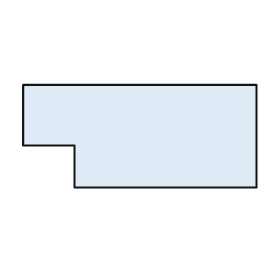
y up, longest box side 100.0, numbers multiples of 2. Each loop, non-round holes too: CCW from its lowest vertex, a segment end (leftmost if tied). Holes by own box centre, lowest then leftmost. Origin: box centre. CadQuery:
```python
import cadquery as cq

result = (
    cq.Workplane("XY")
    .moveTo(-28.0, -22.0)
    .lineTo(50.0, -22.0)
    .lineTo(50.0, 22.0)
    .lineTo(-50.0, 22.0)
    .lineTo(-50.0, -4.0)
    .lineTo(-28.0, -4.0)
    .close()
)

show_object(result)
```